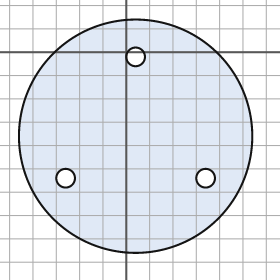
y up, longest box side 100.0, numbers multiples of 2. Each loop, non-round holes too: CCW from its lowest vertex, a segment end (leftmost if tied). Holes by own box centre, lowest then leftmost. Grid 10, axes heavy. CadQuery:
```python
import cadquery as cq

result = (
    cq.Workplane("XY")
    .moveTo(4.0, -36.0)
    .circle(50.0)
    .moveTo(-26.0, -54.0)
    .circle(4.0)
    .moveTo(34.0, -54.0)
    .circle(4.0)
    .moveTo(4.0, -2.0)
    .circle(4.0)
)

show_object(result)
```